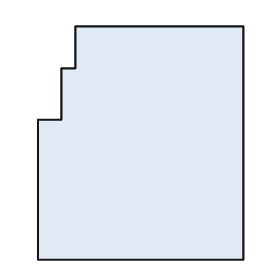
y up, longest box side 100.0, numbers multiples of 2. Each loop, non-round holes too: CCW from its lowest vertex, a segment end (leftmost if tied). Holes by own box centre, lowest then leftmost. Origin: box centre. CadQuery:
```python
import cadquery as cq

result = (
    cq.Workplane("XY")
    .moveTo(-44.0, -50.0)
    .lineTo(44.0, -50.0)
    .lineTo(44.0, 50.0)
    .lineTo(-28.0, 50.0)
    .lineTo(-28.0, 32.0)
    .lineTo(-34.0, 32.0)
    .lineTo(-34.0, 10.0)
    .lineTo(-44.0, 10.0)
    .close()
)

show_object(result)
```